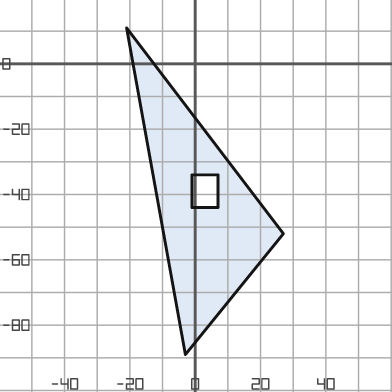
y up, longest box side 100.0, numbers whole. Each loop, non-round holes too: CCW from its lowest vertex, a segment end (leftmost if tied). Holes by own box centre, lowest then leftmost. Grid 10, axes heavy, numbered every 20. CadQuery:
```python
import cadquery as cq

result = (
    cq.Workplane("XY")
    .moveTo(-3.0, -89.0)
    .lineTo(27.0, -52.0)
    .lineTo(-21.0, 11.0)
    .close()
    .moveTo(-1.0, -44.0)
    .lineTo(7.0, -44.0)
    .lineTo(7.0, -34.0)
    .lineTo(-1.0, -34.0)
    .close()
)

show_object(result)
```